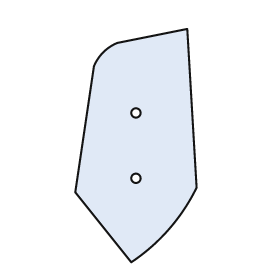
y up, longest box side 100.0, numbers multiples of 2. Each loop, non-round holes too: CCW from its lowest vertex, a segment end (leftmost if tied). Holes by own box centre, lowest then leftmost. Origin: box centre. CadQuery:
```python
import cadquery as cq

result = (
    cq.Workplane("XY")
    .moveTo(-2.0, -50.0)
    .threePointArc((14.0, -36.0), (26.0, -18.0))
    .lineTo(22.0, 50.0)
    .lineTo(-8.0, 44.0)
    .threePointArc((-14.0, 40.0), (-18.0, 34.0))
    .lineTo(-26.0, -20.0)
    .close()
    .moveTo(0.0, -14.0)
    .circle(2.0)
    .moveTo(0.0, 14.0)
    .circle(2.0)
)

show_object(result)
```